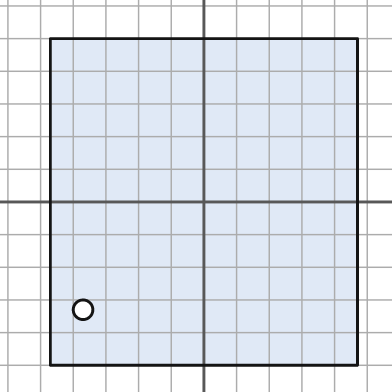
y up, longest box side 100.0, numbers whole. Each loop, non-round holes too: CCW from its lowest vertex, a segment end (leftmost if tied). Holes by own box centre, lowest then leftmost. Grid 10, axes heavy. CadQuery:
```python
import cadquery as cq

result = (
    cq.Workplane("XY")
    .moveTo(-47.0, -50.0)
    .lineTo(47.0, -50.0)
    .lineTo(47.0, 50.0)
    .lineTo(-47.0, 50.0)
    .close()
    .moveTo(-37.0, -33.0)
    .circle(3.0)
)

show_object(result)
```